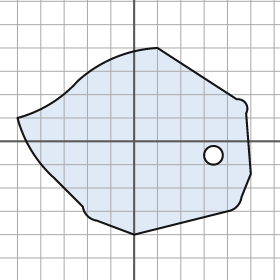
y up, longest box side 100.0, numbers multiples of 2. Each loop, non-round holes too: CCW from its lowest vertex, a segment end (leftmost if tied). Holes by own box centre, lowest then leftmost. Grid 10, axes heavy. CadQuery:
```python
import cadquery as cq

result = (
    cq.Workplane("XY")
    .moveTo(0.0, -40.0)
    .lineTo(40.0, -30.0)
    .threePointArc((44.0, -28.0), (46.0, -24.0))
    .lineTo(50.0, -14.0)
    .lineTo(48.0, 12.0)
    .threePointArc((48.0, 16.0), (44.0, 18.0))
    .lineTo(10.0, 40.0)
    .threePointArc((-8.0, 36.0), (-24.0, 26.0))
    .threePointArc((-36.0, 16.0), (-50.0, 10.0))
    .threePointArc((-44.0, -4.0), (-34.0, -16.0))
    .lineTo(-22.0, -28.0)
    .threePointArc((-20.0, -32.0), (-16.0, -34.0))
    .close()
    .moveTo(34.0, -6.0)
    .circle(4.0)
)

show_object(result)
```